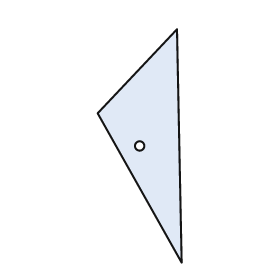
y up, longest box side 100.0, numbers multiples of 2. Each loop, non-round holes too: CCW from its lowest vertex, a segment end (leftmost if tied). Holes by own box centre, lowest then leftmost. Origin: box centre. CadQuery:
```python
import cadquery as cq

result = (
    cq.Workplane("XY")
    .moveTo(18.0, -50.0)
    .lineTo(16.0, 50.0)
    .lineTo(-18.0, 14.0)
    .close()
    .moveTo(0.0, 0.0)
    .circle(2.0)
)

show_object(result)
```